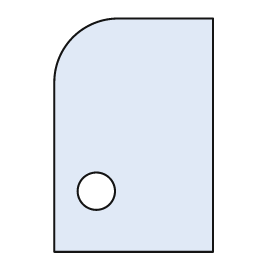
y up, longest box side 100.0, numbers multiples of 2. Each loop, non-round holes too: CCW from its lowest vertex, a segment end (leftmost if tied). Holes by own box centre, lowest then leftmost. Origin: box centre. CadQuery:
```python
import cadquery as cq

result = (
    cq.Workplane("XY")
    .moveTo(-34.0, -50.0)
    .lineTo(34.0, -50.0)
    .lineTo(34.0, 50.0)
    .lineTo(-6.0, 50.0)
    .threePointArc((-26.0, 42.0), (-34.0, 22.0))
    .close()
    .moveTo(-16.0, -24.0)
    .circle(8.0)
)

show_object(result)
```